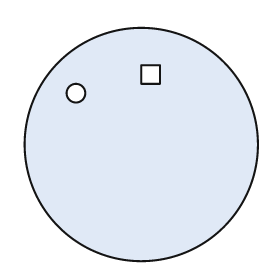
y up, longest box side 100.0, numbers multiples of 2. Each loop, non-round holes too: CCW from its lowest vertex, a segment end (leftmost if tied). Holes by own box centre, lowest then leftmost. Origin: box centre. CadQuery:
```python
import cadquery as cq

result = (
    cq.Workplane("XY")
    .moveTo(0.0, 0.0)
    .circle(50.0)
    .moveTo(-28.0, 22.0)
    .circle(4.0)
    .moveTo(0.0, 26.0)
    .lineTo(8.0, 26.0)
    .lineTo(8.0, 34.0)
    .lineTo(0.0, 34.0)
    .close()
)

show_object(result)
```